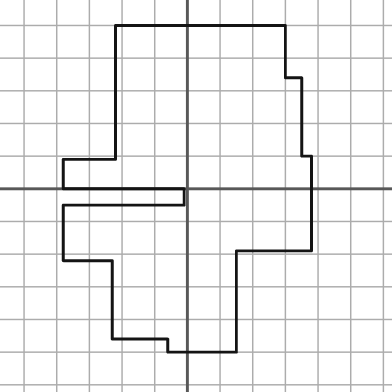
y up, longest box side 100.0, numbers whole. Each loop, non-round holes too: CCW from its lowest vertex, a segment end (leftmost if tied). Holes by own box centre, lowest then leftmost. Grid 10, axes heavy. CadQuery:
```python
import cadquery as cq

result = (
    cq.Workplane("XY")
    .moveTo(-6.0, -50.0)
    .lineTo(15.0, -50.0)
    .lineTo(15.0, -19.0)
    .lineTo(38.0, -19.0)
    .lineTo(38.0, 10.0)
    .lineTo(35.0, 10.0)
    .lineTo(35.0, 34.0)
    .lineTo(30.0, 34.0)
    .lineTo(30.0, 50.0)
    .lineTo(-22.0, 50.0)
    .lineTo(-22.0, 9.0)
    .lineTo(-38.0, 9.0)
    .lineTo(-38.0, 0.0)
    .lineTo(-1.0, 0.0)
    .lineTo(-1.0, -5.0)
    .lineTo(-38.0, -5.0)
    .lineTo(-38.0, -22.0)
    .lineTo(-23.0, -22.0)
    .lineTo(-23.0, -46.0)
    .lineTo(-6.0, -46.0)
    .close()
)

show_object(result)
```